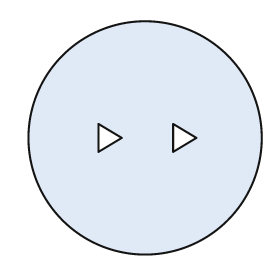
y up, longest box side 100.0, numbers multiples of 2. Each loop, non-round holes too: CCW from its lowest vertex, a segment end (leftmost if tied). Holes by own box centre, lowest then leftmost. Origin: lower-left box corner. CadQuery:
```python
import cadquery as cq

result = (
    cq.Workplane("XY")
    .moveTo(50.0, 50.0)
    .circle(50.0)
    .moveTo(30.0, 44.0)
    .lineTo(40.0, 50.0)
    .lineTo(30.0, 56.0)
    .close()
    .moveTo(62.0, 44.0)
    .lineTo(72.0, 50.0)
    .lineTo(62.0, 56.0)
    .close()
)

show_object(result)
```